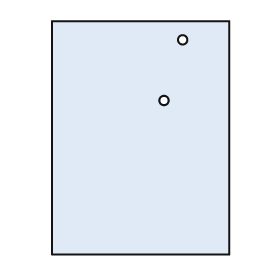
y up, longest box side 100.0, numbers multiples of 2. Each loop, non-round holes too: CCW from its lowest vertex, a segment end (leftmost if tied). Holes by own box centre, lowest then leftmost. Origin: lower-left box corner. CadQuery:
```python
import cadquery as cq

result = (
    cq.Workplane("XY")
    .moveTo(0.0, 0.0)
    .lineTo(76.0, 0.0)
    .lineTo(76.0, 100.0)
    .lineTo(0.0, 100.0)
    .close()
    .moveTo(48.0, 66.0)
    .circle(2.0)
    .moveTo(56.0, 92.0)
    .circle(2.0)
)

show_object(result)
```